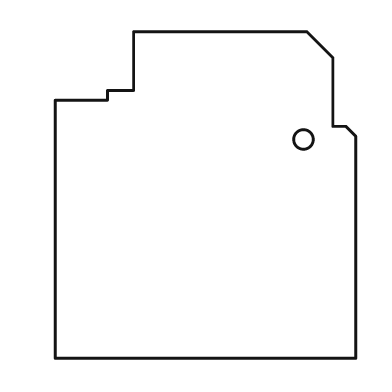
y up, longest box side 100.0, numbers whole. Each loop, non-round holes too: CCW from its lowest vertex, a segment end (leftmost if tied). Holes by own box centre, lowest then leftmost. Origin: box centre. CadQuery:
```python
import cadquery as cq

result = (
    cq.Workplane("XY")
    .moveTo(-46.0, -50.0)
    .lineTo(46.0, -50.0)
    .lineTo(46.0, 18.0)
    .lineTo(43.0, 21.0)
    .lineTo(39.0, 21.0)
    .lineTo(39.0, 42.0)
    .lineTo(31.0, 50.0)
    .lineTo(-22.0, 50.0)
    .lineTo(-22.0, 32.0)
    .lineTo(-30.0, 32.0)
    .lineTo(-30.0, 29.0)
    .lineTo(-46.0, 29.0)
    .close()
    .moveTo(30.0, 17.0)
    .circle(3.0)
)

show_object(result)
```